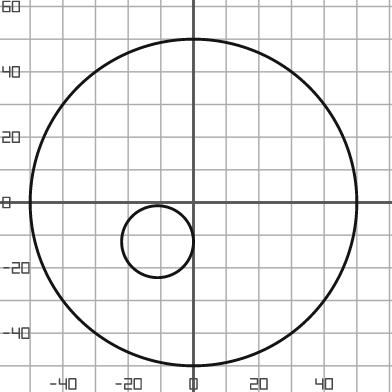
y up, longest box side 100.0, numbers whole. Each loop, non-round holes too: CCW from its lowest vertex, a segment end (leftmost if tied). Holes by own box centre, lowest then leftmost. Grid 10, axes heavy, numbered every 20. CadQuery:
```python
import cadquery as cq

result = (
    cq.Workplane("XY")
    .moveTo(0.0, 0.0)
    .circle(50.0)
    .moveTo(-11.0, -12.0)
    .circle(11.0)
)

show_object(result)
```